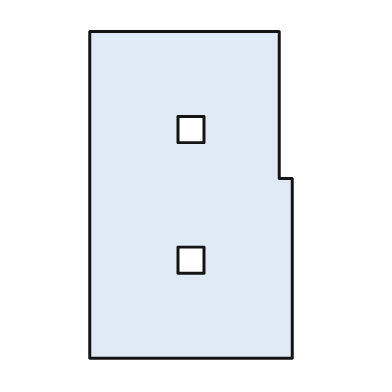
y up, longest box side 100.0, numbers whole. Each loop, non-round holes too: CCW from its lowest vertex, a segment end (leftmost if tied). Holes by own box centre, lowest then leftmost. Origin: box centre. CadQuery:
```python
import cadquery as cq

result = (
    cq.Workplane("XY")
    .moveTo(-31.0, -50.0)
    .lineTo(31.0, -50.0)
    .lineTo(31.0, 5.0)
    .lineTo(27.0, 5.0)
    .lineTo(27.0, 50.0)
    .lineTo(-31.0, 50.0)
    .close()
    .moveTo(-4.0, -24.0)
    .lineTo(4.0, -24.0)
    .lineTo(4.0, -16.0)
    .lineTo(-4.0, -16.0)
    .close()
    .moveTo(-4.0, 16.0)
    .lineTo(4.0, 16.0)
    .lineTo(4.0, 24.0)
    .lineTo(-4.0, 24.0)
    .close()
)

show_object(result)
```